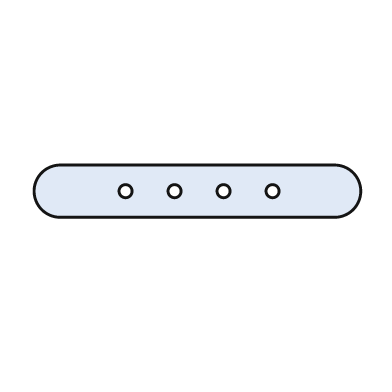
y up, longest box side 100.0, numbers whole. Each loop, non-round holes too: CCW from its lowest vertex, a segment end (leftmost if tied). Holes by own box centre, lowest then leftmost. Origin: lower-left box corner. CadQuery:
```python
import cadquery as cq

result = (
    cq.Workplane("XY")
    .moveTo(8.0, 0.0)
    .lineTo(92.0, 0.0)
    .threePointArc((100.0, 8.0), (92.0, 16.0))
    .lineTo(8.0, 16.0)
    .threePointArc((0.0, 8.0), (8.0, 0.0))
    .close()
    .moveTo(28.0, 8.0)
    .circle(2.0)
    .moveTo(43.0, 8.0)
    .circle(2.0)
    .moveTo(58.0, 8.0)
    .circle(2.0)
    .moveTo(73.0, 8.0)
    .circle(2.0)
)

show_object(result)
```